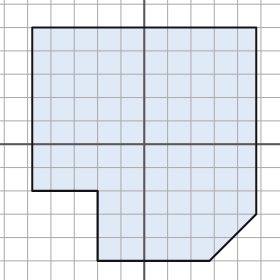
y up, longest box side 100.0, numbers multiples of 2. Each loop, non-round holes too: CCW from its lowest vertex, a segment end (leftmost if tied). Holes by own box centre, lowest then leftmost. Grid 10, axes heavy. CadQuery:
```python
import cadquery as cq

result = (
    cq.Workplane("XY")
    .moveTo(-20.0, -50.0)
    .lineTo(28.0, -50.0)
    .lineTo(48.0, -30.0)
    .lineTo(48.0, 50.0)
    .lineTo(-48.0, 50.0)
    .lineTo(-48.0, -20.0)
    .lineTo(-20.0, -20.0)
    .close()
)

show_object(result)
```